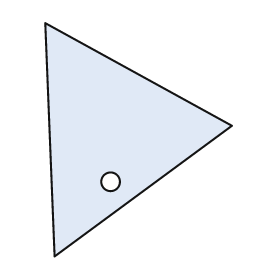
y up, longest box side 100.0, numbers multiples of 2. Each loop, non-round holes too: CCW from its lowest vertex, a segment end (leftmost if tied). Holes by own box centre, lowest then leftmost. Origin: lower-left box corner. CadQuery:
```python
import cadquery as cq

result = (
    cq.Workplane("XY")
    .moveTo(4.0, 0.0)
    .lineTo(80.0, 56.0)
    .lineTo(0.0, 100.0)
    .close()
    .moveTo(28.0, 32.0)
    .circle(4.0)
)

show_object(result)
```